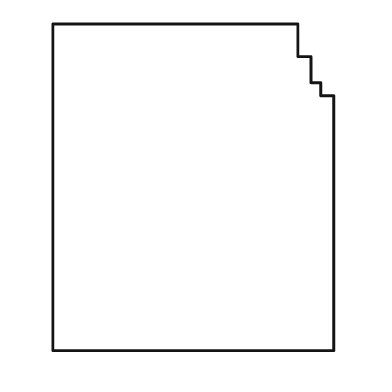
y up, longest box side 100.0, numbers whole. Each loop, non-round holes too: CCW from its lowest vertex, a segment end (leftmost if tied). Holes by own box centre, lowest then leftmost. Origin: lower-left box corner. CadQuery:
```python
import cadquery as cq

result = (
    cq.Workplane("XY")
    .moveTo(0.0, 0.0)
    .lineTo(86.0, 0.0)
    .lineTo(86.0, 78.0)
    .lineTo(82.0, 78.0)
    .lineTo(82.0, 82.0)
    .lineTo(79.0, 82.0)
    .lineTo(79.0, 90.0)
    .lineTo(75.0, 90.0)
    .lineTo(75.0, 100.0)
    .lineTo(0.0, 100.0)
    .close()
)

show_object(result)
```